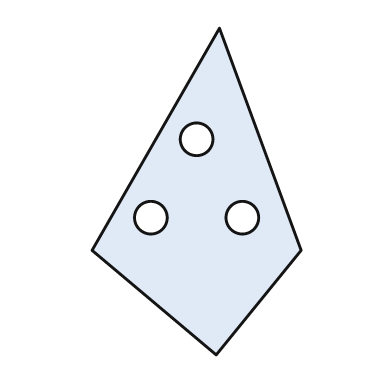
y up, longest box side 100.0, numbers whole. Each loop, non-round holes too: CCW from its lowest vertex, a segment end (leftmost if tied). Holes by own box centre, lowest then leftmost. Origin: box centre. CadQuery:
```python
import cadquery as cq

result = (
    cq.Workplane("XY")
    .moveTo(6.0, -50.0)
    .lineTo(32.0, -18.0)
    .lineTo(7.0, 50.0)
    .lineTo(-32.0, -18.0)
    .close()
    .moveTo(-14.0, -8.0)
    .circle(5.0)
    .moveTo(14.0, -8.0)
    .circle(5.0)
    .moveTo(0.0, 16.0)
    .circle(5.0)
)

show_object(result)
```